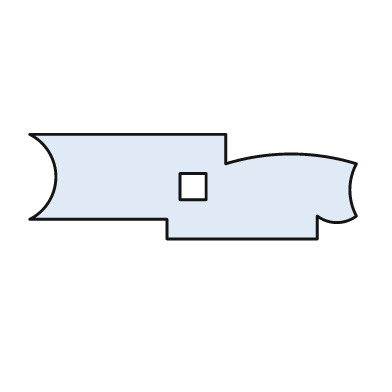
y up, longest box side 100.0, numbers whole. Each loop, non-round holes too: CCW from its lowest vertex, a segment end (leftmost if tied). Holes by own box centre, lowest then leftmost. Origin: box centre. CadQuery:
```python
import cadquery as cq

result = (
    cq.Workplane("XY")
    .moveTo(-8.0, -16.0)
    .lineTo(38.0, -16.0)
    .lineTo(38.0, -9.0)
    .threePointArc((44.0, -11.0), (50.0, -9.0))
    .threePointArc((48.0, -1.0), (50.0, 7.0))
    .threePointArc((30.0, 10.0), (10.0, 7.0))
    .lineTo(10.0, 16.0)
    .lineTo(-50.0, 16.0)
    .threePointArc((-42.0, 3.0), (-50.0, -10.0))
    .lineTo(-8.0, -10.0)
    .close()
    .moveTo(-4.0, -4.0)
    .lineTo(4.0, -4.0)
    .lineTo(4.0, 4.0)
    .lineTo(-4.0, 4.0)
    .close()
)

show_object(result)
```